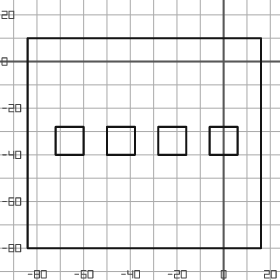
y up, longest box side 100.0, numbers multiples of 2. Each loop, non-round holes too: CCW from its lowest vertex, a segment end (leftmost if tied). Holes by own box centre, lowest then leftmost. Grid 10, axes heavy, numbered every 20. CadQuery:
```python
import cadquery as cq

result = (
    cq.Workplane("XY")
    .moveTo(-84.0, -80.0)
    .lineTo(16.0, -80.0)
    .lineTo(16.0, 10.0)
    .lineTo(-84.0, 10.0)
    .close()
    .moveTo(-72.0, -40.0)
    .lineTo(-60.0, -40.0)
    .lineTo(-60.0, -28.0)
    .lineTo(-72.0, -28.0)
    .close()
    .moveTo(-50.0, -40.0)
    .lineTo(-38.0, -40.0)
    .lineTo(-38.0, -28.0)
    .lineTo(-50.0, -28.0)
    .close()
    .moveTo(-28.0, -40.0)
    .lineTo(-16.0, -40.0)
    .lineTo(-16.0, -28.0)
    .lineTo(-28.0, -28.0)
    .close()
    .moveTo(-6.0, -40.0)
    .lineTo(6.0, -40.0)
    .lineTo(6.0, -28.0)
    .lineTo(-6.0, -28.0)
    .close()
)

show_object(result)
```